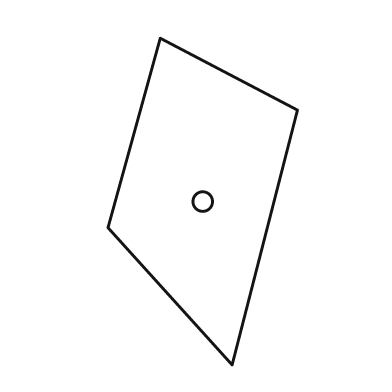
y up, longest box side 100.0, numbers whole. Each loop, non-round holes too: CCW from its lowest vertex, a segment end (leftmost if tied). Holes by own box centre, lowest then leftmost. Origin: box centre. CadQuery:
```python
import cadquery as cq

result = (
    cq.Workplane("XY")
    .moveTo(9.0, -50.0)
    .lineTo(29.0, 28.0)
    .lineTo(-13.0, 50.0)
    .lineTo(-29.0, -8.0)
    .close()
    .moveTo(0.0, 0.0)
    .circle(3.0)
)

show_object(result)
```